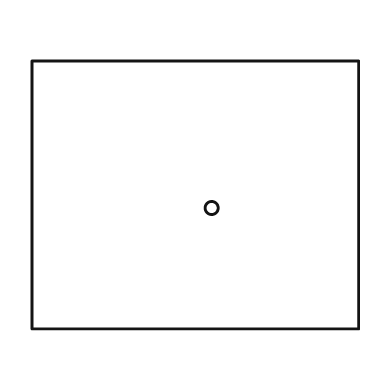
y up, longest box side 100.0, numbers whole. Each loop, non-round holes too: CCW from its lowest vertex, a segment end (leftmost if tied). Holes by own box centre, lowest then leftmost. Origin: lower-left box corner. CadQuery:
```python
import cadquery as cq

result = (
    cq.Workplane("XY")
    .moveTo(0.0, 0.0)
    .lineTo(100.0, 0.0)
    .lineTo(100.0, 82.0)
    .lineTo(0.0, 82.0)
    .close()
    .moveTo(55.0, 37.0)
    .circle(2.0)
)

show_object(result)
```